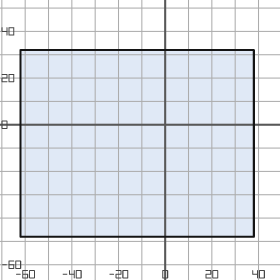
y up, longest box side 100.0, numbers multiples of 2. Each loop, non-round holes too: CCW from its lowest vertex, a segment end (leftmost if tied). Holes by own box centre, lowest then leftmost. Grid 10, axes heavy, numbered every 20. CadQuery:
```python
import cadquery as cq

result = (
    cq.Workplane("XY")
    .moveTo(-62.0, -48.0)
    .lineTo(38.0, -48.0)
    .lineTo(38.0, 32.0)
    .lineTo(-62.0, 32.0)
    .close()
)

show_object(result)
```